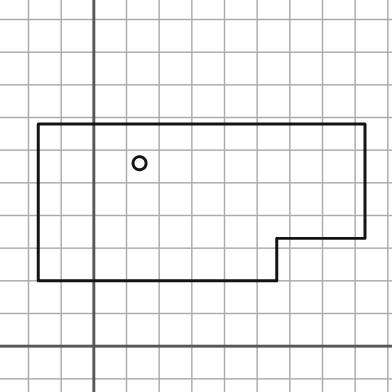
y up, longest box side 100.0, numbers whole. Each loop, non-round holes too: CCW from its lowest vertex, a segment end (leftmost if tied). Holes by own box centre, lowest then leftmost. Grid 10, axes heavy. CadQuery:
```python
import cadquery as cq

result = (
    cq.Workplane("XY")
    .moveTo(-17.0, 20.0)
    .lineTo(56.0, 20.0)
    .lineTo(56.0, 33.0)
    .lineTo(83.0, 33.0)
    .lineTo(83.0, 68.0)
    .lineTo(-17.0, 68.0)
    .close()
    .moveTo(14.0, 56.0)
    .circle(2.0)
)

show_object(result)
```